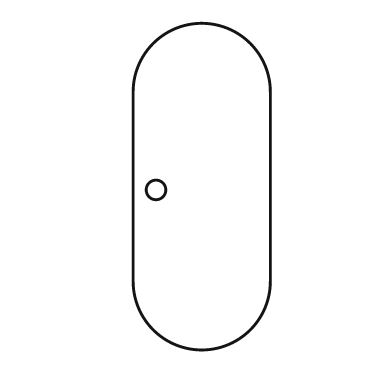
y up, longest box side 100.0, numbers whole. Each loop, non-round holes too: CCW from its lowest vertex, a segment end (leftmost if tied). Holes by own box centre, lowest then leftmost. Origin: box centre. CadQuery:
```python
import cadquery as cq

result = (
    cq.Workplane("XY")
    .moveTo(-21.0, -29.0)
    .threePointArc((0.0, -50.0), (21.0, -29.0))
    .lineTo(21.0, 29.0)
    .threePointArc((0.0, 50.0), (-21.0, 29.0))
    .close()
    .moveTo(-14.0, -1.0)
    .circle(3.0)
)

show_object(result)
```